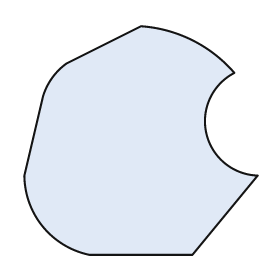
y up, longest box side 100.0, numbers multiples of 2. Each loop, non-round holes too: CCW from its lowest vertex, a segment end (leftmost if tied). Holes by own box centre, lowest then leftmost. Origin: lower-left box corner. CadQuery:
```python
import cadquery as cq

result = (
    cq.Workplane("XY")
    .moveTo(28.0, 0.0)
    .lineTo(72.0, 0.0)
    .lineTo(100.0, 34.0)
    .threePointArc((78.0, 52.0), (90.0, 78.0))
    .threePointArc((72.0, 92.0), (50.0, 98.0))
    .lineTo(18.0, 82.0)
    .threePointArc((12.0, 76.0), (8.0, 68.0))
    .lineTo(0.0, 34.0)
    .threePointArc((8.0, 12.0), (28.0, 0.0))
    .close()
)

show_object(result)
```